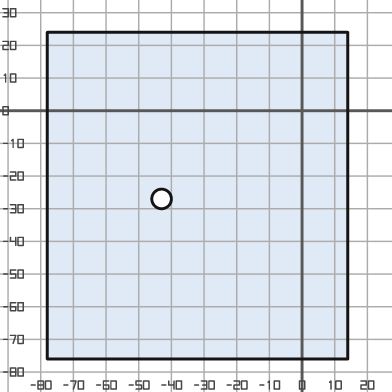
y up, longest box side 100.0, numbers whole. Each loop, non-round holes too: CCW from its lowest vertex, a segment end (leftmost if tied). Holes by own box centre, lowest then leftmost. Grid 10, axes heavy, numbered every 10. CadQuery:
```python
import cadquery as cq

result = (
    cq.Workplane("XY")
    .moveTo(-78.0, -76.0)
    .lineTo(14.0, -76.0)
    .lineTo(14.0, 24.0)
    .lineTo(-78.0, 24.0)
    .close()
    .moveTo(-43.0, -27.0)
    .circle(3.0)
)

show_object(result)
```